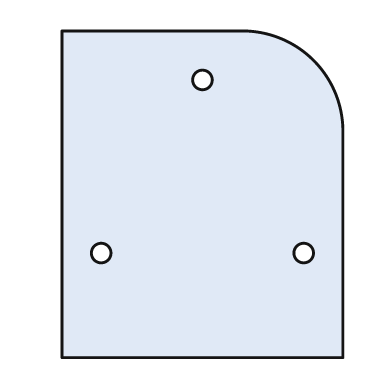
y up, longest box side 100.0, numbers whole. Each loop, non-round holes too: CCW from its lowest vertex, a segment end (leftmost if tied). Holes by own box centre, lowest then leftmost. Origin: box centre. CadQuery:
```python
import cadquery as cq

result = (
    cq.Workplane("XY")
    .moveTo(-43.0, -50.0)
    .lineTo(43.0, -50.0)
    .lineTo(43.0, 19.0)
    .threePointArc((34.0, 41.0), (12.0, 50.0))
    .lineTo(-43.0, 50.0)
    .close()
    .moveTo(-31.0, -18.0)
    .circle(3.0)
    .moveTo(31.0, -18.0)
    .circle(3.0)
    .moveTo(0.0, 35.0)
    .circle(3.0)
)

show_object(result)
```